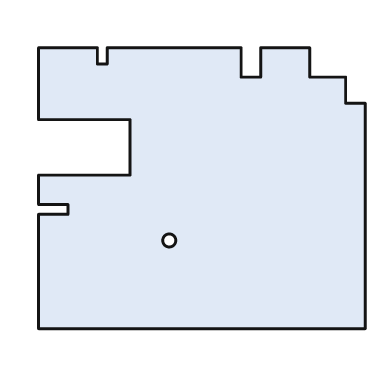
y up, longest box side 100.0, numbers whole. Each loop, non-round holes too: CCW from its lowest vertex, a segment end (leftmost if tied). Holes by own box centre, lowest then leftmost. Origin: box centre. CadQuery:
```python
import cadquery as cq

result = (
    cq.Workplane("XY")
    .moveTo(-50.0, -43.0)
    .lineTo(50.0, -43.0)
    .lineTo(50.0, 26.0)
    .lineTo(44.0, 26.0)
    .lineTo(44.0, 34.0)
    .lineTo(33.0, 34.0)
    .lineTo(33.0, 43.0)
    .lineTo(18.0, 43.0)
    .lineTo(18.0, 34.0)
    .lineTo(12.0, 34.0)
    .lineTo(12.0, 43.0)
    .lineTo(-29.0, 43.0)
    .lineTo(-29.0, 38.0)
    .lineTo(-32.0, 38.0)
    .lineTo(-32.0, 43.0)
    .lineTo(-50.0, 43.0)
    .lineTo(-50.0, 21.0)
    .lineTo(-22.0, 21.0)
    .lineTo(-22.0, 4.0)
    .lineTo(-50.0, 4.0)
    .lineTo(-50.0, -5.0)
    .lineTo(-41.0, -5.0)
    .lineTo(-41.0, -8.0)
    .lineTo(-50.0, -8.0)
    .close()
    .moveTo(-10.0, -16.0)
    .circle(2.0)
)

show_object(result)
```